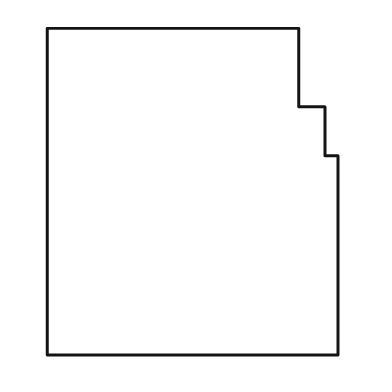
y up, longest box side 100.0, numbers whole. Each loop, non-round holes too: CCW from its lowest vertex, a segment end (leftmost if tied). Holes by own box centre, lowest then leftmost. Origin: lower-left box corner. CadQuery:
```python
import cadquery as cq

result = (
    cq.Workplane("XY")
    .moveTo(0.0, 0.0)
    .lineTo(89.0, 0.0)
    .lineTo(89.0, 61.0)
    .lineTo(85.0, 61.0)
    .lineTo(85.0, 76.0)
    .lineTo(77.0, 76.0)
    .lineTo(77.0, 100.0)
    .lineTo(0.0, 100.0)
    .close()
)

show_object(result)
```